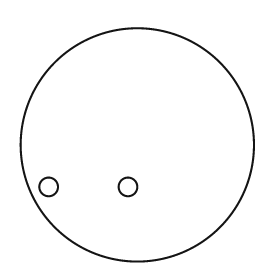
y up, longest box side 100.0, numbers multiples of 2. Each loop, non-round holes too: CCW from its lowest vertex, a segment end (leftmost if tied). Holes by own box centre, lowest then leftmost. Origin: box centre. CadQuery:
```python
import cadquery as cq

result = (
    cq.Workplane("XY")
    .moveTo(0.0, 0.0)
    .circle(50.0)
    .moveTo(-38.0, -18.0)
    .circle(4.0)
    .moveTo(-4.0, -18.0)
    .circle(4.0)
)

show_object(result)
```